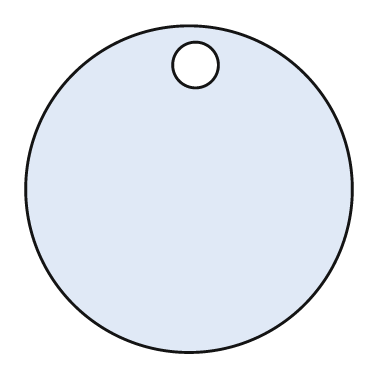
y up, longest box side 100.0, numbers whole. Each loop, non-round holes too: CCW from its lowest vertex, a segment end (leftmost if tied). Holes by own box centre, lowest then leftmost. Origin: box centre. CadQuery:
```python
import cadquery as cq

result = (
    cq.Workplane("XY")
    .moveTo(0.0, 0.0)
    .circle(50.0)
    .moveTo(2.0, 38.0)
    .circle(7.0)
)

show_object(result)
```